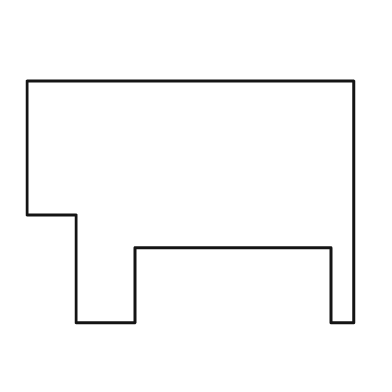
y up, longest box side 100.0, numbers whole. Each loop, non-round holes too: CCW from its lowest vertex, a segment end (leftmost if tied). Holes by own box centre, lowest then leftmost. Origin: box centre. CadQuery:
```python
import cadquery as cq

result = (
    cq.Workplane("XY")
    .moveTo(-35.0, -37.0)
    .lineTo(-17.0, -37.0)
    .lineTo(-17.0, -14.0)
    .lineTo(43.0, -14.0)
    .lineTo(43.0, -37.0)
    .lineTo(50.0, -37.0)
    .lineTo(50.0, 37.0)
    .lineTo(-50.0, 37.0)
    .lineTo(-50.0, -4.0)
    .lineTo(-35.0, -4.0)
    .close()
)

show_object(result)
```